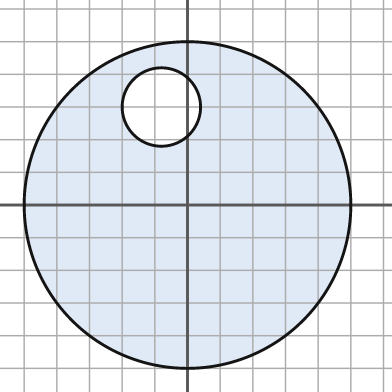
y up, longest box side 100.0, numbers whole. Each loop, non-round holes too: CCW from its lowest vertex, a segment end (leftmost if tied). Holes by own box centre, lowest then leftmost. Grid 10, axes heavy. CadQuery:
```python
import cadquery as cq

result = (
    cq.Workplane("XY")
    .moveTo(0.0, 0.0)
    .circle(50.0)
    .moveTo(-8.0, 30.0)
    .circle(12.0)
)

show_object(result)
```